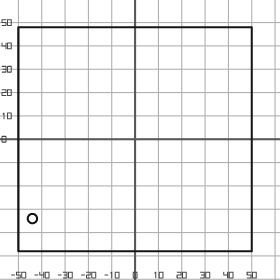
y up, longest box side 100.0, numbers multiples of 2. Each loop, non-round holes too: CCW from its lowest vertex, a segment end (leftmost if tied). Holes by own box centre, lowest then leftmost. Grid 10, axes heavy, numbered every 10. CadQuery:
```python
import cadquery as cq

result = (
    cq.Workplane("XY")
    .moveTo(-50.0, -48.0)
    .lineTo(50.0, -48.0)
    .lineTo(50.0, 48.0)
    .lineTo(-50.0, 48.0)
    .close()
    .moveTo(-44.0, -34.0)
    .circle(2.0)
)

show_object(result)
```